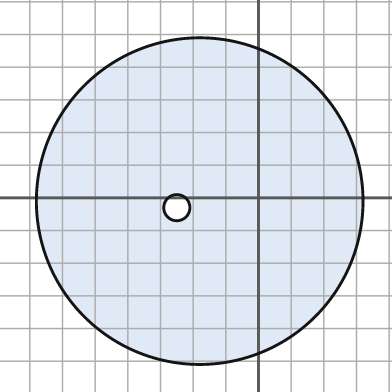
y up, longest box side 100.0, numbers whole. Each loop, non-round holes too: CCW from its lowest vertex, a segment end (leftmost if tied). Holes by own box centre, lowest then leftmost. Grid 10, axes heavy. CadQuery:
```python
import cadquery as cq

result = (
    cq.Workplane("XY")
    .moveTo(-18.0, -1.0)
    .circle(50.0)
    .moveTo(-25.0, -3.0)
    .circle(4.0)
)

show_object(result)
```